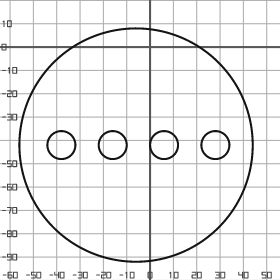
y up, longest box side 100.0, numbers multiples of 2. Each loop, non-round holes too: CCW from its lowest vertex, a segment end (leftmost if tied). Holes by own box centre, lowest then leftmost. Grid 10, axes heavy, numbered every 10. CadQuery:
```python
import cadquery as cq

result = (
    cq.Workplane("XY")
    .moveTo(-6.0, -42.0)
    .circle(50.0)
    .moveTo(-38.0, -42.0)
    .circle(6.0)
    .moveTo(-16.0, -42.0)
    .circle(6.0)
    .moveTo(6.0, -42.0)
    .circle(6.0)
    .moveTo(28.0, -42.0)
    .circle(6.0)
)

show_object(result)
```